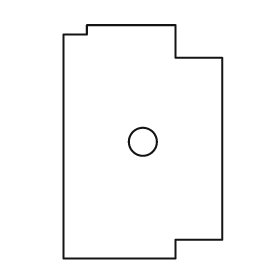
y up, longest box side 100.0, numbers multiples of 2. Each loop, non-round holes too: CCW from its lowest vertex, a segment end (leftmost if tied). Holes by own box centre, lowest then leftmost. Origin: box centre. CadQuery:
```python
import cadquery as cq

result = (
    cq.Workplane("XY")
    .moveTo(-34.0, -50.0)
    .lineTo(14.0, -50.0)
    .lineTo(14.0, -42.0)
    .lineTo(34.0, -42.0)
    .lineTo(34.0, 36.0)
    .lineTo(14.0, 36.0)
    .lineTo(14.0, 50.0)
    .lineTo(-24.0, 50.0)
    .lineTo(-24.0, 46.0)
    .lineTo(-34.0, 46.0)
    .close()
    .moveTo(0.0, 0.0)
    .circle(6.0)
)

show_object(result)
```